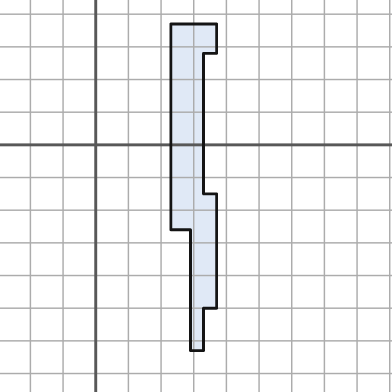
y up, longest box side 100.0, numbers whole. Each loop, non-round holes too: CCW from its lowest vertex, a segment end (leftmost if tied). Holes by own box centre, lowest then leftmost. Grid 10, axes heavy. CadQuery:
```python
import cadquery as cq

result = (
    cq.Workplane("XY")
    .moveTo(29.0, -63.0)
    .lineTo(33.0, -63.0)
    .lineTo(33.0, -50.0)
    .lineTo(37.0, -50.0)
    .lineTo(37.0, -15.0)
    .lineTo(33.0, -15.0)
    .lineTo(33.0, 28.0)
    .lineTo(37.0, 28.0)
    .lineTo(37.0, 37.0)
    .lineTo(23.0, 37.0)
    .lineTo(23.0, -26.0)
    .lineTo(29.0, -26.0)
    .close()
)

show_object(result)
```